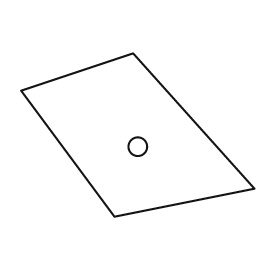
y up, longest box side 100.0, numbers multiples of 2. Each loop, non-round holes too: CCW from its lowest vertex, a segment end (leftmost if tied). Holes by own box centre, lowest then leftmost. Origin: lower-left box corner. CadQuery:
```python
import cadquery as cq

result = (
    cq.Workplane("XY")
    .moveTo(40.0, 0.0)
    .lineTo(100.0, 12.0)
    .lineTo(48.0, 70.0)
    .lineTo(0.0, 54.0)
    .close()
    .moveTo(50.0, 30.0)
    .circle(4.0)
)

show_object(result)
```